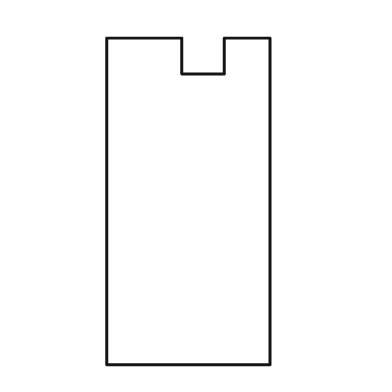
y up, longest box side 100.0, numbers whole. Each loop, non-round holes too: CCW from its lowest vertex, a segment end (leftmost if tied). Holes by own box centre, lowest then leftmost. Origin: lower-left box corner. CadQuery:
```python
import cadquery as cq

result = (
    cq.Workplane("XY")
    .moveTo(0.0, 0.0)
    .lineTo(50.0, 0.0)
    .lineTo(50.0, 100.0)
    .lineTo(36.0, 100.0)
    .lineTo(36.0, 89.0)
    .lineTo(23.0, 89.0)
    .lineTo(23.0, 100.0)
    .lineTo(0.0, 100.0)
    .close()
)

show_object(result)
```